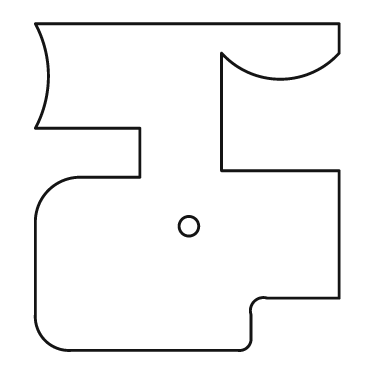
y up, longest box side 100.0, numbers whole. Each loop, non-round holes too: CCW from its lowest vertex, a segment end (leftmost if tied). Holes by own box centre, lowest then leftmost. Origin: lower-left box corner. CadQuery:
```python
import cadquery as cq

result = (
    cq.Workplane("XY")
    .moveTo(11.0, 0.0)
    .lineTo(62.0, 0.0)
    .threePointArc((65.0, 1.0), (66.0, 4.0))
    .lineTo(66.0, 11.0)
    .threePointArc((67.0, 15.0), (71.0, 16.0))
    .lineTo(93.0, 16.0)
    .lineTo(93.0, 55.0)
    .lineTo(57.0, 55.0)
    .lineTo(57.0, 91.0)
    .threePointArc((75.0, 83.0), (93.0, 91.0))
    .lineTo(93.0, 100.0)
    .lineTo(0.0, 100.0)
    .threePointArc((4.0, 84.0), (0.0, 68.0))
    .lineTo(32.0, 68.0)
    .lineTo(32.0, 53.0)
    .lineTo(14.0, 53.0)
    .threePointArc((4.0, 49.0), (0.0, 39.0))
    .lineTo(0.0, 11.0)
    .threePointArc((3.0, 3.0), (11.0, 0.0))
    .close()
    .moveTo(47.0, 38.0)
    .circle(3.0)
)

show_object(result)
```